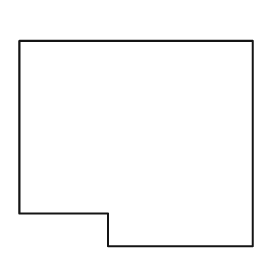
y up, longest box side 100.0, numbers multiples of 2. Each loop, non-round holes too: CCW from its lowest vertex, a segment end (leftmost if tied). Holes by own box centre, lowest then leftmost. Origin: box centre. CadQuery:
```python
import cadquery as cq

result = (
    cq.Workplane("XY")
    .moveTo(-12.0, -44.0)
    .lineTo(50.0, -44.0)
    .lineTo(50.0, 44.0)
    .lineTo(-50.0, 44.0)
    .lineTo(-50.0, -30.0)
    .lineTo(-12.0, -30.0)
    .close()
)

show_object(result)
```